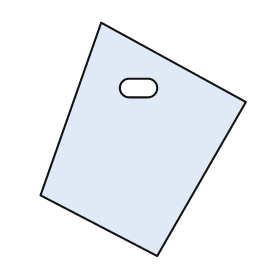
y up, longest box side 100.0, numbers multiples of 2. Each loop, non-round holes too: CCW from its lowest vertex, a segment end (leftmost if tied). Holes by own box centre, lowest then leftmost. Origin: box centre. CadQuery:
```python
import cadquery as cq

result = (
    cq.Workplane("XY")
    .moveTo(6.0, -50.0)
    .lineTo(44.0, 16.0)
    .lineTo(-18.0, 50.0)
    .lineTo(-44.0, -24.0)
    .close()
    .moveTo(-6.0, 18.0)
    .lineTo(2.0, 18.0)
    .threePointArc((6.0, 22.0), (2.0, 26.0))
    .lineTo(-6.0, 26.0)
    .threePointArc((-10.0, 22.0), (-6.0, 18.0))
    .close()
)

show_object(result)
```